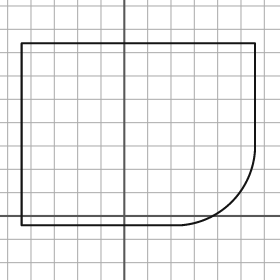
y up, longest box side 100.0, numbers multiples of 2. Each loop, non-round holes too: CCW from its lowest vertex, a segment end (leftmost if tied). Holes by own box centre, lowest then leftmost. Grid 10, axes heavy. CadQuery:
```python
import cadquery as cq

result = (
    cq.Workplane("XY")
    .moveTo(-44.0, -4.0)
    .lineTo(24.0, -4.0)
    .threePointArc((46.0, 6.0), (56.0, 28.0))
    .lineTo(56.0, 74.0)
    .lineTo(-44.0, 74.0)
    .close()
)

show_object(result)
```